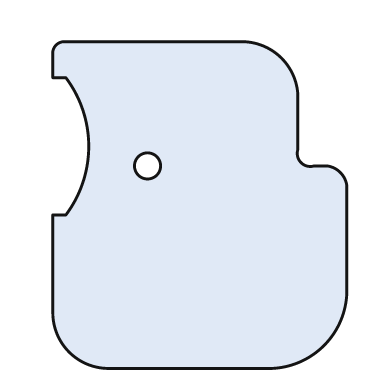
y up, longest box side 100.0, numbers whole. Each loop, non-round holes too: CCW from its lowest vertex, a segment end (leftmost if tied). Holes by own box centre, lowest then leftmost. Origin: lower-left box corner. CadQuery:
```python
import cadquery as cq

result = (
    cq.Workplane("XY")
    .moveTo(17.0, 0.0)
    .lineTo(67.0, 0.0)
    .threePointArc((83.0, 7.0), (90.0, 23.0))
    .lineTo(90.0, 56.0)
    .threePointArc((88.0, 60.0), (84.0, 62.0))
    .lineTo(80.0, 62.0)
    .threePointArc((76.0, 63.0), (75.0, 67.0))
    .lineTo(75.0, 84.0)
    .threePointArc((70.0, 95.0), (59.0, 100.0))
    .lineTo(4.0, 100.0)
    .threePointArc((1.0, 99.0), (0.0, 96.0))
    .lineTo(0.0, 89.0)
    .lineTo(4.0, 89.0)
    .threePointArc((11.0, 68.0), (4.0, 47.0))
    .lineTo(0.0, 47.0)
    .lineTo(0.0, 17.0)
    .threePointArc((5.0, 5.0), (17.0, 0.0))
    .close()
    .moveTo(29.0, 62.0)
    .circle(4.0)
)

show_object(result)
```